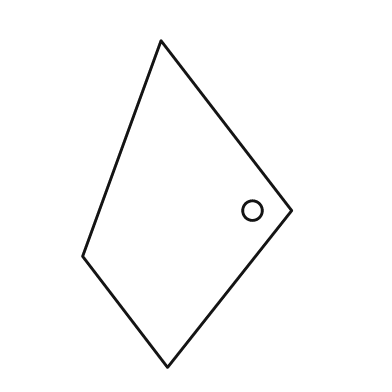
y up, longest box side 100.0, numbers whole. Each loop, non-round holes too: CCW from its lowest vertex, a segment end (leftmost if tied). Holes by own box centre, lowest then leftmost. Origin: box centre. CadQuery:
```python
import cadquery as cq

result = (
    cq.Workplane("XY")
    .moveTo(-6.0, -50.0)
    .lineTo(32.0, -2.0)
    .lineTo(-8.0, 50.0)
    .lineTo(-32.0, -16.0)
    .close()
    .moveTo(20.0, -2.0)
    .circle(3.0)
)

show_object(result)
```